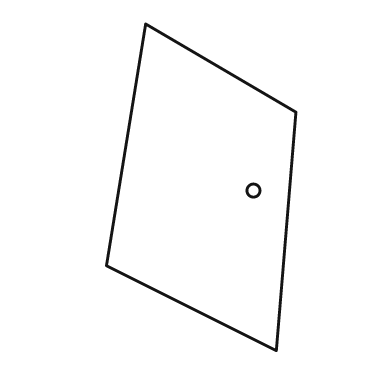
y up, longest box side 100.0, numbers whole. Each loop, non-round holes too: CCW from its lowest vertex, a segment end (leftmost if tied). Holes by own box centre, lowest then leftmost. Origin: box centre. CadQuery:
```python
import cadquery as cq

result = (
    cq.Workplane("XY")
    .moveTo(23.0, -50.0)
    .lineTo(29.0, 23.0)
    .lineTo(-17.0, 50.0)
    .lineTo(-29.0, -24.0)
    .close()
    .moveTo(16.0, -1.0)
    .circle(2.0)
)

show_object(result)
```